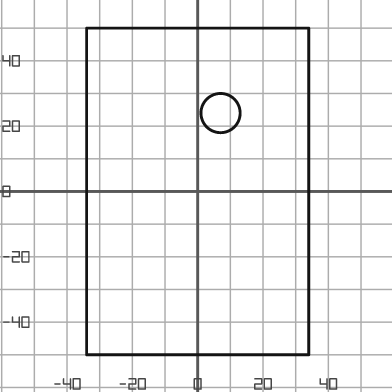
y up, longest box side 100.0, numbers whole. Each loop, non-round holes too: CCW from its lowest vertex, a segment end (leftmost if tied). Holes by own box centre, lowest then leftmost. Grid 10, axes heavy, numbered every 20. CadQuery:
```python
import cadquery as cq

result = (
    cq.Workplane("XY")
    .moveTo(-34.0, -50.0)
    .lineTo(34.0, -50.0)
    .lineTo(34.0, 50.0)
    .lineTo(-34.0, 50.0)
    .close()
    .moveTo(7.0, 24.0)
    .circle(6.0)
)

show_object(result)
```